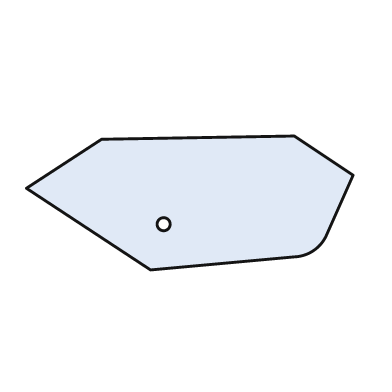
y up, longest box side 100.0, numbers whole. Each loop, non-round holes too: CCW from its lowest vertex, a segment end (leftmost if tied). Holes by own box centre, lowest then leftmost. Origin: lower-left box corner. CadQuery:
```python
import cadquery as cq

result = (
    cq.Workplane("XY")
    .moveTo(38.0, 0.0)
    .lineTo(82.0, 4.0)
    .threePointArc((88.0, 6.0), (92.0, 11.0))
    .lineTo(100.0, 29.0)
    .lineTo(82.0, 41.0)
    .lineTo(23.0, 40.0)
    .lineTo(0.0, 25.0)
    .close()
    .moveTo(42.0, 14.0)
    .circle(2.0)
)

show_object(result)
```